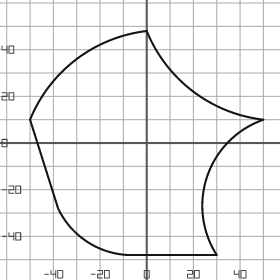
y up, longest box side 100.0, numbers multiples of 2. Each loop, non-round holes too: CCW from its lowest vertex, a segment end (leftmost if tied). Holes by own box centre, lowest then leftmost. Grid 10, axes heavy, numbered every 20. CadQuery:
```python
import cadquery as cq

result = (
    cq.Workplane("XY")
    .moveTo(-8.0, -48.0)
    .lineTo(30.0, -48.0)
    .threePointArc((26.0, -14.0), (50.0, 10.0))
    .threePointArc((20.0, 22.0), (0.0, 48.0))
    .threePointArc((-30.0, 36.0), (-50.0, 10.0))
    .lineTo(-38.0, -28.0)
    .threePointArc((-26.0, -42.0), (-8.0, -48.0))
    .close()
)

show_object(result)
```